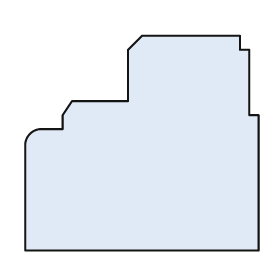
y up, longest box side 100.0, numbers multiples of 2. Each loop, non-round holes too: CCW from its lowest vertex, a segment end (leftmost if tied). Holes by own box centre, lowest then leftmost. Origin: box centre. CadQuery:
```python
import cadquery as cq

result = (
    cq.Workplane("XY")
    .moveTo(-50.0, -46.0)
    .lineTo(50.0, -46.0)
    .lineTo(50.0, 12.0)
    .lineTo(46.0, 12.0)
    .lineTo(46.0, 40.0)
    .lineTo(42.0, 40.0)
    .lineTo(42.0, 46.0)
    .lineTo(0.0, 46.0)
    .lineTo(-6.0, 40.0)
    .lineTo(-6.0, 18.0)
    .lineTo(-30.0, 18.0)
    .lineTo(-34.0, 12.0)
    .lineTo(-34.0, 6.0)
    .lineTo(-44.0, 6.0)
    .threePointArc((-48.0, 4.0), (-50.0, 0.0))
    .close()
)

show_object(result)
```